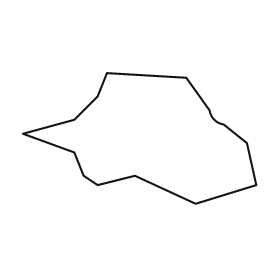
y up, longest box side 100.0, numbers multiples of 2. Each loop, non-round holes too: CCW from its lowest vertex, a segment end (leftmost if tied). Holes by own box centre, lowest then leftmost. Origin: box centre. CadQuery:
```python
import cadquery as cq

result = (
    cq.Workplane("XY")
    .moveTo(24.0, -28.0)
    .lineTo(50.0, -20.0)
    .lineTo(46.0, -2.0)
    .lineTo(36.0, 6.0)
    .threePointArc((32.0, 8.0), (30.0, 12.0))
    .lineTo(20.0, 26.0)
    .lineTo(-14.0, 28.0)
    .lineTo(-18.0, 18.0)
    .lineTo(-28.0, 8.0)
    .lineTo(-50.0, 2.0)
    .lineTo(-28.0, -6.0)
    .lineTo(-24.0, -16.0)
    .lineTo(-18.0, -20.0)
    .lineTo(-2.0, -16.0)
    .close()
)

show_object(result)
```